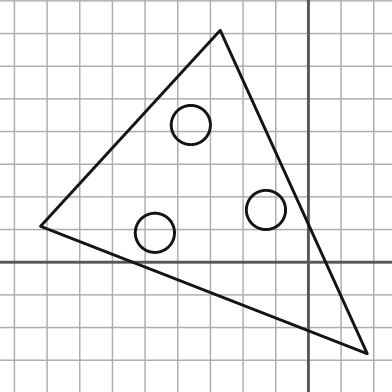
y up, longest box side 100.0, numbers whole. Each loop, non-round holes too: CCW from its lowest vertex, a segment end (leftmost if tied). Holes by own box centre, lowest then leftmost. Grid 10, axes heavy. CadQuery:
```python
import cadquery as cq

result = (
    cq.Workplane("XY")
    .moveTo(18.0, -28.0)
    .lineTo(-27.0, 71.0)
    .lineTo(-82.0, 11.0)
    .close()
    .moveTo(-47.0, 9.0)
    .circle(6.0)
    .moveTo(-13.0, 16.0)
    .circle(6.0)
    .moveTo(-36.0, 42.0)
    .circle(6.0)
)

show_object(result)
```